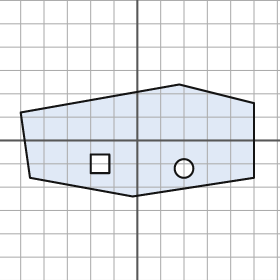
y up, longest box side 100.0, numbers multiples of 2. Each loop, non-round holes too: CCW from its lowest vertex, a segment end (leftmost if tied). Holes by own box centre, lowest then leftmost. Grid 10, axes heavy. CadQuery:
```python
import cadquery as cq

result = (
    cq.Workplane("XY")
    .moveTo(-2.0, -24.0)
    .lineTo(50.0, -16.0)
    .lineTo(50.0, 16.0)
    .lineTo(18.0, 24.0)
    .lineTo(-50.0, 12.0)
    .lineTo(-46.0, -16.0)
    .close()
    .moveTo(20.0, -12.0)
    .circle(4.0)
    .moveTo(-20.0, -14.0)
    .lineTo(-12.0, -14.0)
    .lineTo(-12.0, -6.0)
    .lineTo(-20.0, -6.0)
    .close()
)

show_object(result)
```